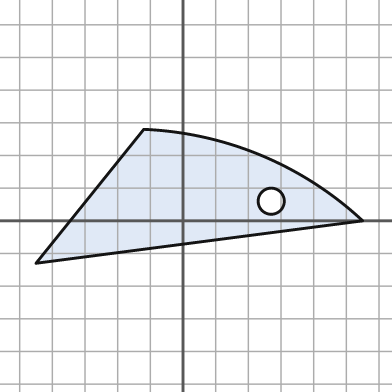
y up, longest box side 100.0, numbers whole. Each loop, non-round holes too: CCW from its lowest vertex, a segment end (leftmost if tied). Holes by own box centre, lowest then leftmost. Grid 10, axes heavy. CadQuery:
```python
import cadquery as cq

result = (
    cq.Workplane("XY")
    .moveTo(-45.0, -13.0)
    .lineTo(55.0, 0.0)
    .threePointArc((24.0, 20.0), (-12.0, 28.0))
    .close()
    .moveTo(27.0, 6.0)
    .circle(4.0)
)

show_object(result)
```